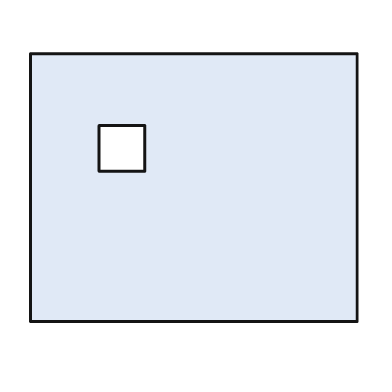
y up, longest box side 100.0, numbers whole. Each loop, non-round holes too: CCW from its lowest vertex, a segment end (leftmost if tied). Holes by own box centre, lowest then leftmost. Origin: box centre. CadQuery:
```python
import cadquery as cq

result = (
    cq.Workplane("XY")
    .moveTo(-50.0, -41.0)
    .lineTo(50.0, -41.0)
    .lineTo(50.0, 41.0)
    .lineTo(-50.0, 41.0)
    .close()
    .moveTo(-29.0, 5.0)
    .lineTo(-15.0, 5.0)
    .lineTo(-15.0, 19.0)
    .lineTo(-29.0, 19.0)
    .close()
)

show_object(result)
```